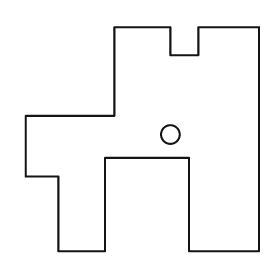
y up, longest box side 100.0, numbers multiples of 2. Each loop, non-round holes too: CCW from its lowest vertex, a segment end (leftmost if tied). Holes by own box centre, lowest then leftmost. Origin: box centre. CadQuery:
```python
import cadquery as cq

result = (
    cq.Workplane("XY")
    .moveTo(-36.0, -48.0)
    .lineTo(-16.0, -48.0)
    .lineTo(-16.0, -8.0)
    .lineTo(20.0, -8.0)
    .lineTo(20.0, -48.0)
    .lineTo(50.0, -48.0)
    .lineTo(50.0, 48.0)
    .lineTo(24.0, 48.0)
    .lineTo(24.0, 36.0)
    .lineTo(12.0, 36.0)
    .lineTo(12.0, 48.0)
    .lineTo(-12.0, 48.0)
    .lineTo(-12.0, 10.0)
    .lineTo(-50.0, 10.0)
    .lineTo(-50.0, -16.0)
    .lineTo(-36.0, -16.0)
    .close()
    .moveTo(12.0, 2.0)
    .circle(4.0)
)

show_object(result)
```